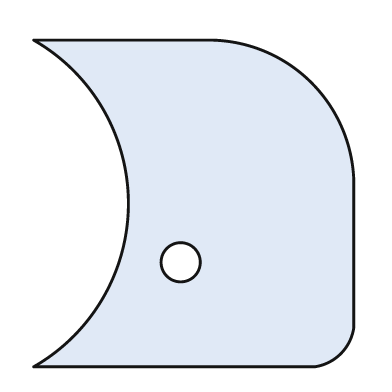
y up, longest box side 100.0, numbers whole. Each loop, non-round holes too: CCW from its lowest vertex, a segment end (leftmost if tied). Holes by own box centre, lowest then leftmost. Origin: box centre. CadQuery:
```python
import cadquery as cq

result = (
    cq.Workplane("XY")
    .moveTo(-49.0, -50.0)
    .lineTo(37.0, -50.0)
    .threePointArc((45.0, -46.0), (49.0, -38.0))
    .lineTo(49.0, 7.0)
    .threePointArc((36.0, 37.0), (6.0, 50.0))
    .lineTo(-49.0, 50.0)
    .threePointArc((-20.0, 0.0), (-49.0, -50.0))
    .close()
    .moveTo(-4.0, -18.0)
    .circle(6.0)
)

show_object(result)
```